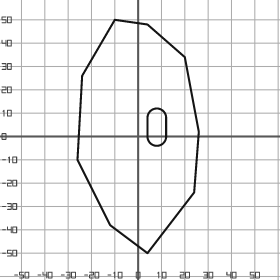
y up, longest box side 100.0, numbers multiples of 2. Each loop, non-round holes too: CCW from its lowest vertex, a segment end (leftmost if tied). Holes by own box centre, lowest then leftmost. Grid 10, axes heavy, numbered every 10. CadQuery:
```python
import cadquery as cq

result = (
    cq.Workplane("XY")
    .moveTo(4.0, -50.0)
    .lineTo(24.0, -24.0)
    .lineTo(26.0, 2.0)
    .lineTo(20.0, 34.0)
    .lineTo(4.0, 48.0)
    .lineTo(-10.0, 50.0)
    .lineTo(-24.0, 26.0)
    .lineTo(-26.0, -10.0)
    .lineTo(-12.0, -38.0)
    .close()
    .moveTo(4.0, 0.0)
    .threePointArc((8.0, -4.0), (12.0, 0.0))
    .lineTo(12.0, 8.0)
    .threePointArc((8.0, 12.0), (4.0, 8.0))
    .close()
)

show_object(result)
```